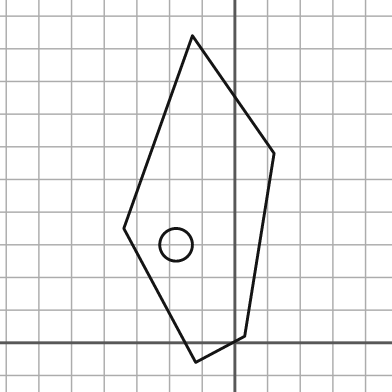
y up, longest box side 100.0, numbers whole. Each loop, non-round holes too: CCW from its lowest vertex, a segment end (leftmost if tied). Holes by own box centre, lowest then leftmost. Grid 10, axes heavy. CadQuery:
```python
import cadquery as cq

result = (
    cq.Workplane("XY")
    .moveTo(-12.0, -6.0)
    .lineTo(3.0, 2.0)
    .lineTo(12.0, 58.0)
    .lineTo(-13.0, 94.0)
    .lineTo(-34.0, 35.0)
    .close()
    .moveTo(-18.0, 30.0)
    .circle(5.0)
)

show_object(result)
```